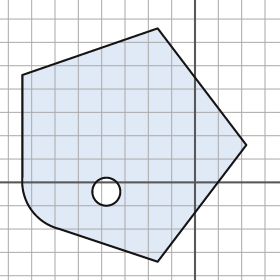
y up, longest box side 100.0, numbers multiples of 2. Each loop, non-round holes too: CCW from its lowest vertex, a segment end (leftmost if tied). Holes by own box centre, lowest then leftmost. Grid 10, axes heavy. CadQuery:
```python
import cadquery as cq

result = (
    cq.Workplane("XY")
    .moveTo(-16.0, -34.0)
    .lineTo(22.0, 16.0)
    .lineTo(-16.0, 66.0)
    .lineTo(-74.0, 46.0)
    .lineTo(-74.0, 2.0)
    .threePointArc((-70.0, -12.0), (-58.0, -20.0))
    .close()
    .moveTo(-38.0, -4.0)
    .circle(6.0)
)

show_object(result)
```